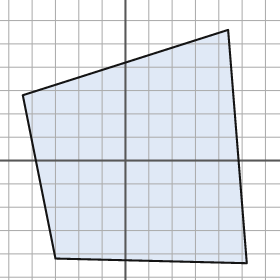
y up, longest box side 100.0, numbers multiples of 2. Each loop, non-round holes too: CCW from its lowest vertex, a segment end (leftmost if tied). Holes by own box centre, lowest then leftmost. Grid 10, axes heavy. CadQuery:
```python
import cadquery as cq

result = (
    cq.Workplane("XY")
    .moveTo(52.0, -44.0)
    .lineTo(44.0, 56.0)
    .lineTo(-44.0, 28.0)
    .lineTo(-30.0, -42.0)
    .close()
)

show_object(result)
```